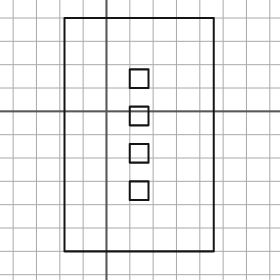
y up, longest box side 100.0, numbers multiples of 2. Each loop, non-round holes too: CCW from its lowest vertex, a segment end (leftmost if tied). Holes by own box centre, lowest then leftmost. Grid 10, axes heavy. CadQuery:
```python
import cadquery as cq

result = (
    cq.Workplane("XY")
    .moveTo(-18.0, -60.0)
    .lineTo(46.0, -60.0)
    .lineTo(46.0, 40.0)
    .lineTo(-18.0, 40.0)
    .close()
    .moveTo(10.0, -38.0)
    .lineTo(18.0, -38.0)
    .lineTo(18.0, -30.0)
    .lineTo(10.0, -30.0)
    .close()
    .moveTo(10.0, -22.0)
    .lineTo(18.0, -22.0)
    .lineTo(18.0, -14.0)
    .lineTo(10.0, -14.0)
    .close()
    .moveTo(10.0, -6.0)
    .lineTo(18.0, -6.0)
    .lineTo(18.0, 2.0)
    .lineTo(10.0, 2.0)
    .close()
    .moveTo(10.0, 10.0)
    .lineTo(18.0, 10.0)
    .lineTo(18.0, 18.0)
    .lineTo(10.0, 18.0)
    .close()
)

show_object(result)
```